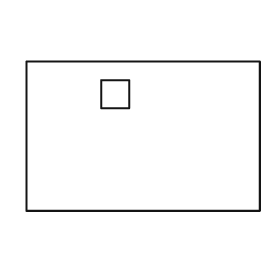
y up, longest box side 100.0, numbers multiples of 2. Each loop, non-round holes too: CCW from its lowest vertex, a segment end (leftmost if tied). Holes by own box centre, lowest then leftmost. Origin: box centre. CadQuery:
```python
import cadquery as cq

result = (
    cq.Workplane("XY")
    .moveTo(-50.0, -32.0)
    .lineTo(50.0, -32.0)
    .lineTo(50.0, 32.0)
    .lineTo(-50.0, 32.0)
    .close()
    .moveTo(-18.0, 12.0)
    .lineTo(-6.0, 12.0)
    .lineTo(-6.0, 24.0)
    .lineTo(-18.0, 24.0)
    .close()
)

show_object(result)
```